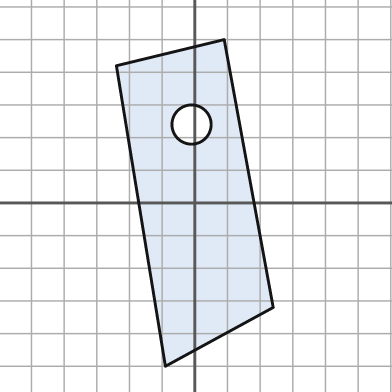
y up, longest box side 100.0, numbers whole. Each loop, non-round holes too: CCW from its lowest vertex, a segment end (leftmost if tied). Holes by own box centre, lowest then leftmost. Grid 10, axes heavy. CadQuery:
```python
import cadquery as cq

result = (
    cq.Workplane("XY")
    .moveTo(-9.0, -50.0)
    .lineTo(24.0, -32.0)
    .lineTo(9.0, 50.0)
    .lineTo(-24.0, 42.0)
    .close()
    .moveTo(-1.0, 24.0)
    .circle(6.0)
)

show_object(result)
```